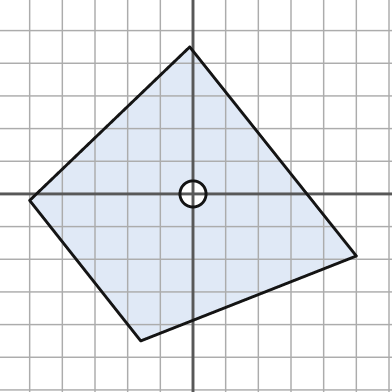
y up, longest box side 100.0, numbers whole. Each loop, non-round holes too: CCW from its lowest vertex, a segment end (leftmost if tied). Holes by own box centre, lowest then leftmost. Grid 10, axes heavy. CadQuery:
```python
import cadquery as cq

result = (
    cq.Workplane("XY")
    .moveTo(-16.0, -45.0)
    .lineTo(50.0, -19.0)
    .lineTo(-1.0, 45.0)
    .lineTo(-50.0, -2.0)
    .close()
    .moveTo(0.0, 0.0)
    .circle(4.0)
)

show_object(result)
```